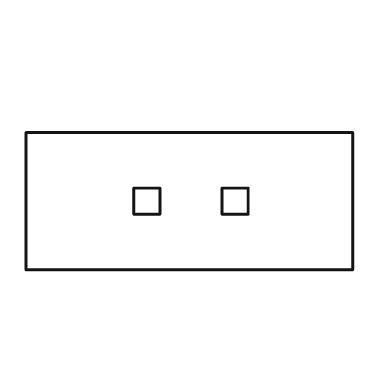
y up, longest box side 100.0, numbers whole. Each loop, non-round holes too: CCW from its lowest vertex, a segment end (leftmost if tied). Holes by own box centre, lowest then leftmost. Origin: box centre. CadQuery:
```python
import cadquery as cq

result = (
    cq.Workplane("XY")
    .moveTo(-50.0, -21.0)
    .lineTo(50.0, -21.0)
    .lineTo(50.0, 21.0)
    .lineTo(-50.0, 21.0)
    .close()
    .moveTo(-17.0, -4.0)
    .lineTo(-9.0, -4.0)
    .lineTo(-9.0, 4.0)
    .lineTo(-17.0, 4.0)
    .close()
    .moveTo(10.0, -4.0)
    .lineTo(18.0, -4.0)
    .lineTo(18.0, 4.0)
    .lineTo(10.0, 4.0)
    .close()
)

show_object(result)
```